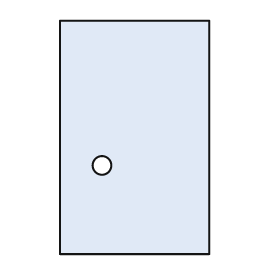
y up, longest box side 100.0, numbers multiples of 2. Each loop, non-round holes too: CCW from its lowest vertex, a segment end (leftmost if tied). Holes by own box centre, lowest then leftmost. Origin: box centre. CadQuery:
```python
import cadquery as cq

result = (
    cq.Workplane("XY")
    .moveTo(-32.0, -50.0)
    .lineTo(32.0, -50.0)
    .lineTo(32.0, 50.0)
    .lineTo(-32.0, 50.0)
    .close()
    .moveTo(-14.0, -12.0)
    .circle(4.0)
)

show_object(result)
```